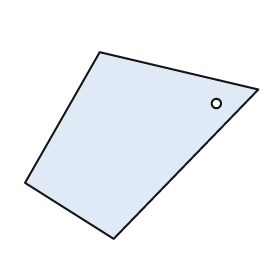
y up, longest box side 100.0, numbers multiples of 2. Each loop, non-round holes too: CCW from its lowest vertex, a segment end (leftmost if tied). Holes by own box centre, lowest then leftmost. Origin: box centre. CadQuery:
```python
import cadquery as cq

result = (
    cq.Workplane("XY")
    .moveTo(-12.0, -40.0)
    .lineTo(50.0, 24.0)
    .lineTo(-18.0, 40.0)
    .lineTo(-50.0, -16.0)
    .close()
    .moveTo(32.0, 18.0)
    .circle(2.0)
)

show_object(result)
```